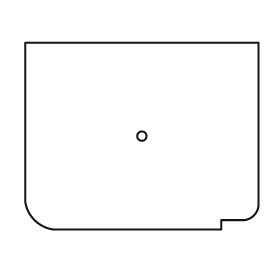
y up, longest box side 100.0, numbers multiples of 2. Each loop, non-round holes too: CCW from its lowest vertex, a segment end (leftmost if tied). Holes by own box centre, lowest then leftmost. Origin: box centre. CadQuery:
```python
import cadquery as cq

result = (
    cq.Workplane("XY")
    .moveTo(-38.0, -40.0)
    .lineTo(34.0, -40.0)
    .lineTo(34.0, -36.0)
    .lineTo(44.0, -36.0)
    .threePointArc((48.0, -34.0), (50.0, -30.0))
    .lineTo(50.0, 40.0)
    .lineTo(-50.0, 40.0)
    .lineTo(-50.0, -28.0)
    .threePointArc((-46.0, -36.0), (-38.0, -40.0))
    .close()
    .moveTo(0.0, 0.0)
    .circle(2.0)
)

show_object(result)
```